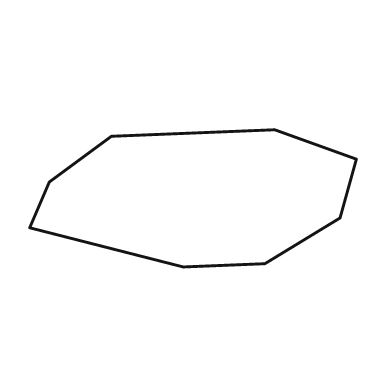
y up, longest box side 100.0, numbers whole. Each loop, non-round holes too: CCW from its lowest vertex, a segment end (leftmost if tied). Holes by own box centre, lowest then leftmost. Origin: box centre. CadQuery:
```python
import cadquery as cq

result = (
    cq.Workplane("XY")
    .moveTo(-3.0, -21.0)
    .lineTo(22.0, -20.0)
    .lineTo(45.0, -6.0)
    .lineTo(50.0, 12.0)
    .lineTo(25.0, 21.0)
    .lineTo(-25.0, 19.0)
    .lineTo(-44.0, 5.0)
    .lineTo(-50.0, -9.0)
    .close()
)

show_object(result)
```